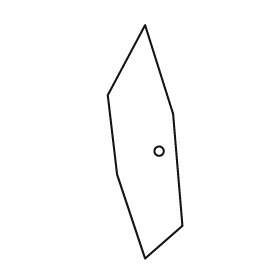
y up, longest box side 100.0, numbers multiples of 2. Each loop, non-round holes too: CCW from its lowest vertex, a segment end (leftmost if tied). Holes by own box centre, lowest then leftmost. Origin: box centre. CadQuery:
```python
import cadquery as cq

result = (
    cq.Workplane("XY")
    .moveTo(0.0, -50.0)
    .lineTo(16.0, -36.0)
    .lineTo(12.0, 12.0)
    .lineTo(0.0, 50.0)
    .lineTo(-16.0, 20.0)
    .lineTo(-12.0, -14.0)
    .close()
    .moveTo(6.0, -4.0)
    .circle(2.0)
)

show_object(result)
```